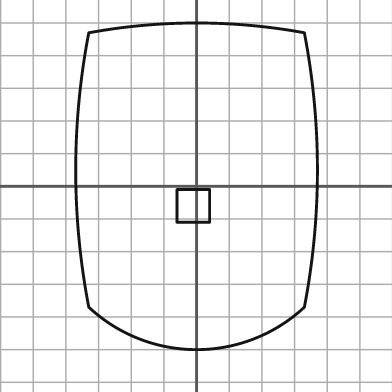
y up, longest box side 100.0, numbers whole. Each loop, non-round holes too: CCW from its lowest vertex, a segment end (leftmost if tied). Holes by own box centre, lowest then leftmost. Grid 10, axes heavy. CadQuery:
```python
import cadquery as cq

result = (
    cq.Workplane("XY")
    .moveTo(-33.0, -37.0)
    .threePointArc((0.0, -50.0), (33.0, -37.0))
    .threePointArc((37.0, 5.0), (33.0, 47.0))
    .threePointArc((0.0, 50.0), (-33.0, 47.0))
    .threePointArc((-37.0, 5.0), (-33.0, -37.0))
    .close()
    .moveTo(-6.0, -11.0)
    .lineTo(4.0, -11.0)
    .lineTo(4.0, -1.0)
    .lineTo(-6.0, -1.0)
    .close()
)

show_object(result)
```